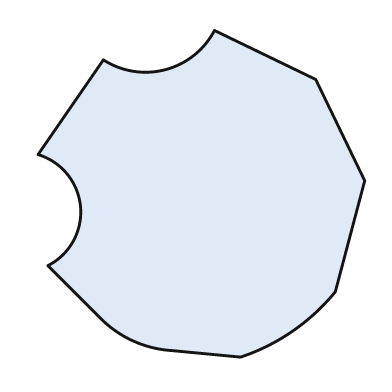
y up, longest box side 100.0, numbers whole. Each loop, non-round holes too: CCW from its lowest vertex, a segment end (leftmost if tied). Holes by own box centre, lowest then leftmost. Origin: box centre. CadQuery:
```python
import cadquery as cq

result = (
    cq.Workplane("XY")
    .moveTo(12.0, -50.0)
    .threePointArc((28.0, -42.0), (41.0, -30.0))
    .lineTo(50.0, 4.0)
    .lineTo(35.0, 35.0)
    .lineTo(4.0, 50.0)
    .threePointArc((-11.0, 38.0), (-30.0, 41.0))
    .lineTo(-50.0, 12.0)
    .threePointArc((-37.0, -4.0), (-47.0, -22.0))
    .lineTo(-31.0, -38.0)
    .threePointArc((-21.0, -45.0), (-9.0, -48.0))
    .close()
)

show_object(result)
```